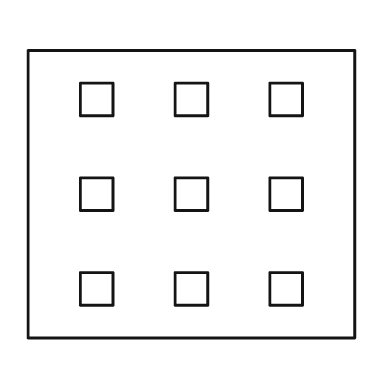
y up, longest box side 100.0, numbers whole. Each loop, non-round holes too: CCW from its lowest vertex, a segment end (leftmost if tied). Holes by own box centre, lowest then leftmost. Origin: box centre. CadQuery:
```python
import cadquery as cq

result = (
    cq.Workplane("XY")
    .moveTo(-50.0, -44.0)
    .lineTo(50.0, -44.0)
    .lineTo(50.0, 44.0)
    .lineTo(-50.0, 44.0)
    .close()
    .moveTo(-34.0, -34.0)
    .lineTo(-24.0, -34.0)
    .lineTo(-24.0, -24.0)
    .lineTo(-34.0, -24.0)
    .close()
    .moveTo(-5.0, -34.0)
    .lineTo(5.0, -34.0)
    .lineTo(5.0, -24.0)
    .lineTo(-5.0, -24.0)
    .close()
    .moveTo(24.0, -34.0)
    .lineTo(34.0, -34.0)
    .lineTo(34.0, -24.0)
    .lineTo(24.0, -24.0)
    .close()
    .moveTo(-34.0, -5.0)
    .lineTo(-24.0, -5.0)
    .lineTo(-24.0, 5.0)
    .lineTo(-34.0, 5.0)
    .close()
    .moveTo(-5.0, -5.0)
    .lineTo(5.0, -5.0)
    .lineTo(5.0, 5.0)
    .lineTo(-5.0, 5.0)
    .close()
    .moveTo(24.0, -5.0)
    .lineTo(34.0, -5.0)
    .lineTo(34.0, 5.0)
    .lineTo(24.0, 5.0)
    .close()
    .moveTo(-34.0, 24.0)
    .lineTo(-24.0, 24.0)
    .lineTo(-24.0, 34.0)
    .lineTo(-34.0, 34.0)
    .close()
    .moveTo(-5.0, 24.0)
    .lineTo(5.0, 24.0)
    .lineTo(5.0, 34.0)
    .lineTo(-5.0, 34.0)
    .close()
    .moveTo(24.0, 24.0)
    .lineTo(34.0, 24.0)
    .lineTo(34.0, 34.0)
    .lineTo(24.0, 34.0)
    .close()
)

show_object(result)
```